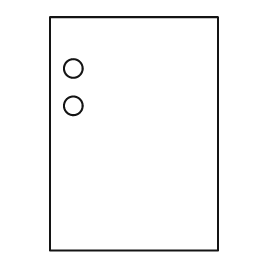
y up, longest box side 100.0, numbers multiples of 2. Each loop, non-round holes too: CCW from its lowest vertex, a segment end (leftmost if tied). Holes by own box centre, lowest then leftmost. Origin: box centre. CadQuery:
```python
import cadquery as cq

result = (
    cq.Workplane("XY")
    .moveTo(-36.0, -50.0)
    .lineTo(36.0, -50.0)
    .lineTo(36.0, 50.0)
    .lineTo(-36.0, 50.0)
    .close()
    .moveTo(-26.0, 12.0)
    .circle(4.0)
    .moveTo(-26.0, 28.0)
    .circle(4.0)
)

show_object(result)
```